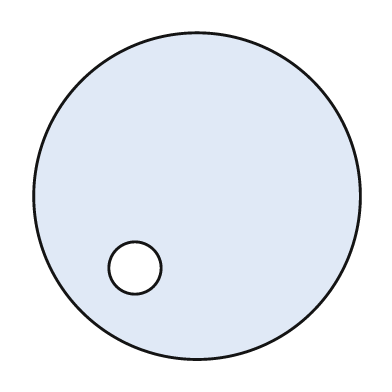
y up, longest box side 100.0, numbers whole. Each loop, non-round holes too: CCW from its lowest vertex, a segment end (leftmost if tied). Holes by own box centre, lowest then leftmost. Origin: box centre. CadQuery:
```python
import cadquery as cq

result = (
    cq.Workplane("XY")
    .moveTo(0.0, 0.0)
    .circle(50.0)
    .moveTo(-19.0, -22.0)
    .circle(8.0)
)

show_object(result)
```